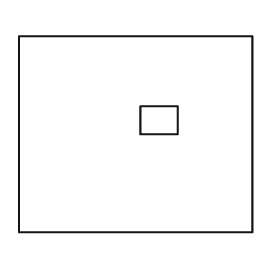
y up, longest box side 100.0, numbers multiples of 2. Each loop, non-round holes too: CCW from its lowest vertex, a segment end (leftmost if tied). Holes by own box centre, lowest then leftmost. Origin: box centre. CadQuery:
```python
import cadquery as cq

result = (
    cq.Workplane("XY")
    .moveTo(-50.0, -42.0)
    .lineTo(50.0, -42.0)
    .lineTo(50.0, 42.0)
    .lineTo(-50.0, 42.0)
    .close()
    .moveTo(2.0, 0.0)
    .lineTo(18.0, 0.0)
    .lineTo(18.0, 12.0)
    .lineTo(2.0, 12.0)
    .close()
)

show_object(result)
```